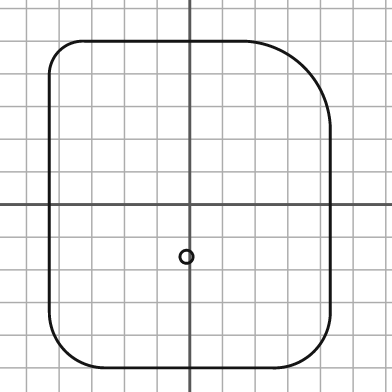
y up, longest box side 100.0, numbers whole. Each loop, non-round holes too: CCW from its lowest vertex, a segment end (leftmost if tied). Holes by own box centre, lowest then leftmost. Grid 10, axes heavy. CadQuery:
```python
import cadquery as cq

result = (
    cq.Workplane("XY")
    .moveTo(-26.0, -50.0)
    .lineTo(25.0, -50.0)
    .threePointArc((38.0, -45.0), (43.0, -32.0))
    .lineTo(43.0, 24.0)
    .threePointArc((35.0, 42.0), (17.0, 50.0))
    .lineTo(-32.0, 50.0)
    .threePointArc((-40.0, 47.0), (-43.0, 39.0))
    .lineTo(-43.0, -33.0)
    .threePointArc((-38.0, -45.0), (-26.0, -50.0))
    .close()
    .moveTo(-1.0, -16.0)
    .circle(2.0)
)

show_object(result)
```